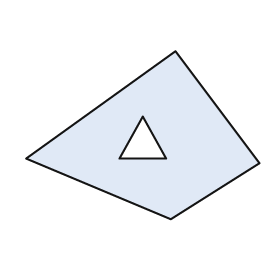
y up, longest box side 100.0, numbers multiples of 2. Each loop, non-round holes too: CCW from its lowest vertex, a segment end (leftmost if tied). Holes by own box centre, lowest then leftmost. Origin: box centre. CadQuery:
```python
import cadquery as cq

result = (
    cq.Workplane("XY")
    .moveTo(12.0, -36.0)
    .lineTo(50.0, -12.0)
    .lineTo(14.0, 36.0)
    .lineTo(-50.0, -10.0)
    .close()
    .moveTo(-10.0, -10.0)
    .lineTo(10.0, -10.0)
    .lineTo(0.0, 8.0)
    .close()
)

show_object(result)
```